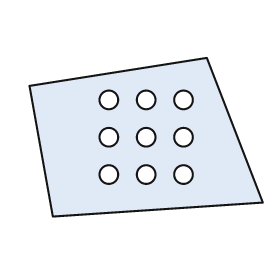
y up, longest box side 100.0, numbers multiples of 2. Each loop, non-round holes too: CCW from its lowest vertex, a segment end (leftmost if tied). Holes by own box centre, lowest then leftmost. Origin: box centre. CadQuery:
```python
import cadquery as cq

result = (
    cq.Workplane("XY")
    .moveTo(-40.0, -34.0)
    .lineTo(50.0, -28.0)
    .lineTo(26.0, 34.0)
    .lineTo(-50.0, 22.0)
    .close()
    .moveTo(-16.0, -16.0)
    .circle(4.0)
    .moveTo(0.0, -16.0)
    .circle(4.0)
    .moveTo(16.0, -16.0)
    .circle(4.0)
    .moveTo(-16.0, 0.0)
    .circle(4.0)
    .moveTo(0.0, 0.0)
    .circle(4.0)
    .moveTo(16.0, 0.0)
    .circle(4.0)
    .moveTo(-16.0, 16.0)
    .circle(4.0)
    .moveTo(0.0, 16.0)
    .circle(4.0)
    .moveTo(16.0, 16.0)
    .circle(4.0)
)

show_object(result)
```